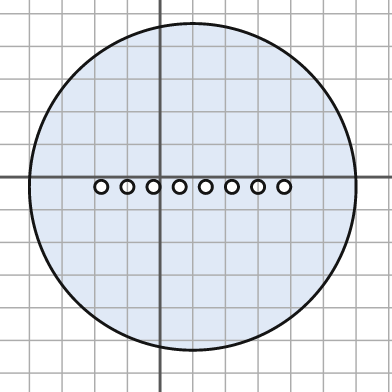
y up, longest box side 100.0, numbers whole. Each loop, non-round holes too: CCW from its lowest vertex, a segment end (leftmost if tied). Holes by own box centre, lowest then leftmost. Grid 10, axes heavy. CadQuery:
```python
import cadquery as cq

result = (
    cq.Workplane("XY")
    .moveTo(10.0, -3.0)
    .circle(50.0)
    .moveTo(-18.0, -3.0)
    .circle(2.0)
    .moveTo(-10.0, -3.0)
    .circle(2.0)
    .moveTo(-2.0, -3.0)
    .circle(2.0)
    .moveTo(6.0, -3.0)
    .circle(2.0)
    .moveTo(14.0, -3.0)
    .circle(2.0)
    .moveTo(22.0, -3.0)
    .circle(2.0)
    .moveTo(30.0, -3.0)
    .circle(2.0)
    .moveTo(38.0, -3.0)
    .circle(2.0)
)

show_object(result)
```